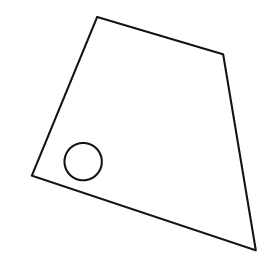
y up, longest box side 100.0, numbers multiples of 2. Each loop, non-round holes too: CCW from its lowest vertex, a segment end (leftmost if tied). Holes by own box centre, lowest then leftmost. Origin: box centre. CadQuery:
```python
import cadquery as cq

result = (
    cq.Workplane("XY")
    .moveTo(48.0, -50.0)
    .lineTo(34.0, 34.0)
    .lineTo(-20.0, 50.0)
    .lineTo(-48.0, -18.0)
    .close()
    .moveTo(-26.0, -12.0)
    .circle(8.0)
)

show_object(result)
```